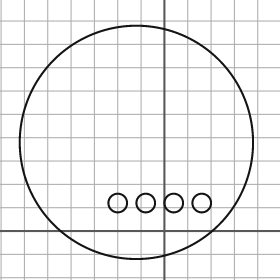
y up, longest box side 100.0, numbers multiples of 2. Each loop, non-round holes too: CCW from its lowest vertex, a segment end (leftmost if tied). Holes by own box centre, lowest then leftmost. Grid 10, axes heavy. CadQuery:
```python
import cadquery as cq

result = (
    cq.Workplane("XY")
    .moveTo(-12.0, 38.0)
    .circle(50.0)
    .moveTo(-20.0, 12.0)
    .circle(4.0)
    .moveTo(-8.0, 12.0)
    .circle(4.0)
    .moveTo(4.0, 12.0)
    .circle(4.0)
    .moveTo(16.0, 12.0)
    .circle(4.0)
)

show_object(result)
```